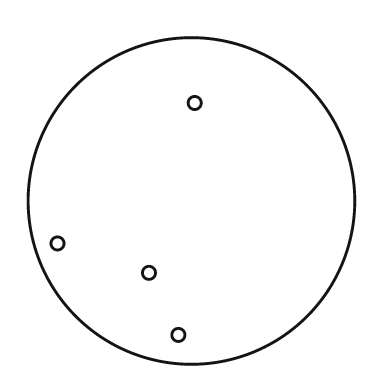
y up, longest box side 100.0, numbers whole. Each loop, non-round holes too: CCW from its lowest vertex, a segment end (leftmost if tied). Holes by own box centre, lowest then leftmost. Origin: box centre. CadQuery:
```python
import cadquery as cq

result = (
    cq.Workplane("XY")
    .moveTo(0.0, 0.0)
    .circle(50.0)
    .moveTo(-4.0, -41.0)
    .circle(2.0)
    .moveTo(-13.0, -22.0)
    .circle(2.0)
    .moveTo(-41.0, -13.0)
    .circle(2.0)
    .moveTo(1.0, 30.0)
    .circle(2.0)
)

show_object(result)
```